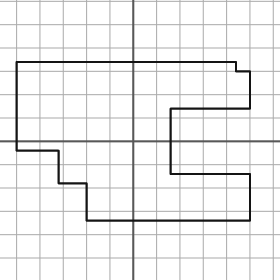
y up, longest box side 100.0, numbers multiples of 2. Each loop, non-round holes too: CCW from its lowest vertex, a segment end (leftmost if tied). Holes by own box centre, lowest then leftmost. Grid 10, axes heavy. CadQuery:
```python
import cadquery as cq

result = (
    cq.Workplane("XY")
    .moveTo(-20.0, -34.0)
    .lineTo(50.0, -34.0)
    .lineTo(50.0, -14.0)
    .lineTo(16.0, -14.0)
    .lineTo(16.0, 14.0)
    .lineTo(50.0, 14.0)
    .lineTo(50.0, 30.0)
    .lineTo(44.0, 30.0)
    .lineTo(44.0, 34.0)
    .lineTo(-50.0, 34.0)
    .lineTo(-50.0, -4.0)
    .lineTo(-32.0, -4.0)
    .lineTo(-32.0, -18.0)
    .lineTo(-20.0, -18.0)
    .close()
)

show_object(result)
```